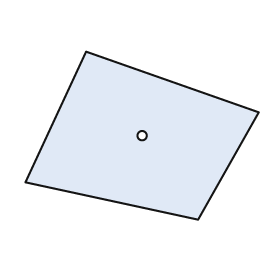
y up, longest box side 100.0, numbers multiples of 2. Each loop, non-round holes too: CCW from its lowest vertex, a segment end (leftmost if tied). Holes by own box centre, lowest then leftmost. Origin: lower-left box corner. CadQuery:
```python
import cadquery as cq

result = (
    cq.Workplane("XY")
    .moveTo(74.0, 0.0)
    .lineTo(100.0, 46.0)
    .lineTo(26.0, 72.0)
    .lineTo(0.0, 16.0)
    .close()
    .moveTo(50.0, 36.0)
    .circle(2.0)
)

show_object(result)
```